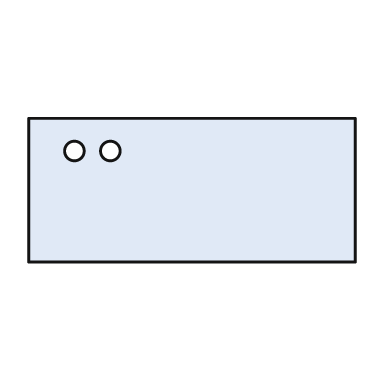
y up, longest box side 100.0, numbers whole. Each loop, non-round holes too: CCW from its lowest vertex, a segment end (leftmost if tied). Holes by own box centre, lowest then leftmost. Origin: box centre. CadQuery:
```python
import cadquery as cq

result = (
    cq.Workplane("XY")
    .moveTo(-50.0, -22.0)
    .lineTo(50.0, -22.0)
    .lineTo(50.0, 22.0)
    .lineTo(-50.0, 22.0)
    .close()
    .moveTo(-36.0, 12.0)
    .circle(3.0)
    .moveTo(-25.0, 12.0)
    .circle(3.0)
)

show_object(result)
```